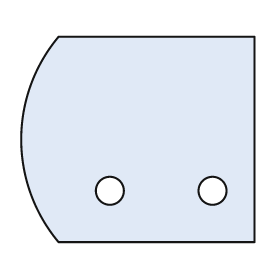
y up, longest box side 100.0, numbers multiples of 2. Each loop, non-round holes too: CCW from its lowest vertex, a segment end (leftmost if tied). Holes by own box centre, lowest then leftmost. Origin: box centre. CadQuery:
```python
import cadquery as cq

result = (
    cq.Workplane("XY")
    .moveTo(-34.0, -44.0)
    .lineTo(50.0, -44.0)
    .lineTo(50.0, 44.0)
    .lineTo(-34.0, 44.0)
    .threePointArc((-50.0, 0.0), (-34.0, -44.0))
    .close()
    .moveTo(-12.0, -22.0)
    .circle(6.0)
    .moveTo(32.0, -22.0)
    .circle(6.0)
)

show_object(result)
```